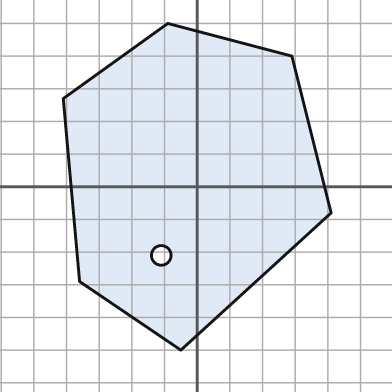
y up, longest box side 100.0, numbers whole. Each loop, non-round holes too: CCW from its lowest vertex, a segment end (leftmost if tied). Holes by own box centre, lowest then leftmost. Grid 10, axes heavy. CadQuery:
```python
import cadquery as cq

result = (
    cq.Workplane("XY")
    .moveTo(-5.0, -50.0)
    .lineTo(41.0, -8.0)
    .lineTo(29.0, 40.0)
    .lineTo(-9.0, 50.0)
    .lineTo(-41.0, 27.0)
    .lineTo(-36.0, -29.0)
    .close()
    .moveTo(-11.0, -21.0)
    .circle(3.0)
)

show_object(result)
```